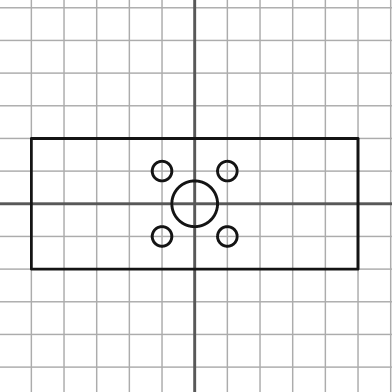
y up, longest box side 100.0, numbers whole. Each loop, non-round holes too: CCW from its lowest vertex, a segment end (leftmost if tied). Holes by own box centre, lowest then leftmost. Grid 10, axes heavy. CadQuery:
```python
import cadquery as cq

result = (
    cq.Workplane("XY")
    .moveTo(-50.0, -20.0)
    .lineTo(50.0, -20.0)
    .lineTo(50.0, 20.0)
    .lineTo(-50.0, 20.0)
    .close()
    .moveTo(-10.0, -10.0)
    .circle(3.0)
    .moveTo(10.0, -10.0)
    .circle(3.0)
    .moveTo(0.0, 0.0)
    .circle(7.0)
    .moveTo(-10.0, 10.0)
    .circle(3.0)
    .moveTo(10.0, 10.0)
    .circle(3.0)
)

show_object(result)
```